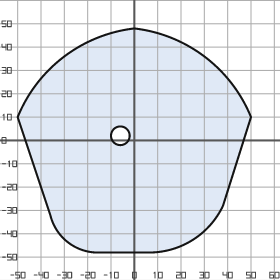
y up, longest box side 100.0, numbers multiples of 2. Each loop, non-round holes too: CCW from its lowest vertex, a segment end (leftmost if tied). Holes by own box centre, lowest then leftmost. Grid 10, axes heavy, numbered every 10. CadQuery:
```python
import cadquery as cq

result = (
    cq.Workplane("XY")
    .moveTo(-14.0, -48.0)
    .lineTo(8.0, -48.0)
    .threePointArc((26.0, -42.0), (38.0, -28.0))
    .lineTo(50.0, 10.0)
    .threePointArc((30.0, 36.0), (0.0, 48.0))
    .threePointArc((-30.0, 36.0), (-50.0, 10.0))
    .lineTo(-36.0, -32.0)
    .threePointArc((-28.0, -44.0), (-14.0, -48.0))
    .close()
    .moveTo(-6.0, 2.0)
    .circle(4.0)
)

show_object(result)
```